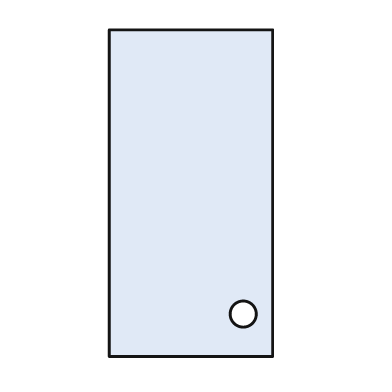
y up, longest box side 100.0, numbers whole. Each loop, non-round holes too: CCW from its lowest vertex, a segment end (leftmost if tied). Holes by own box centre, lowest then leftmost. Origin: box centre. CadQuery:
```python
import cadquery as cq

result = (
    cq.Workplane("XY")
    .moveTo(-25.0, -50.0)
    .lineTo(25.0, -50.0)
    .lineTo(25.0, 50.0)
    .lineTo(-25.0, 50.0)
    .close()
    .moveTo(16.0, -37.0)
    .circle(4.0)
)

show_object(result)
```